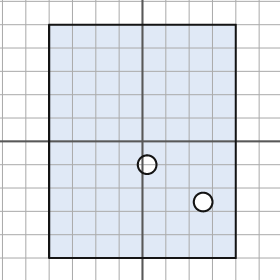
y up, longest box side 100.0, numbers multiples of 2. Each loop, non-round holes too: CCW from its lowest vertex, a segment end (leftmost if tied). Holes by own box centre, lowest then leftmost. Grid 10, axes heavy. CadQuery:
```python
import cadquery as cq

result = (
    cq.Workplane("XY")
    .moveTo(-40.0, -50.0)
    .lineTo(40.0, -50.0)
    .lineTo(40.0, 50.0)
    .lineTo(-40.0, 50.0)
    .close()
    .moveTo(26.0, -26.0)
    .circle(4.0)
    .moveTo(2.0, -10.0)
    .circle(4.0)
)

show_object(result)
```